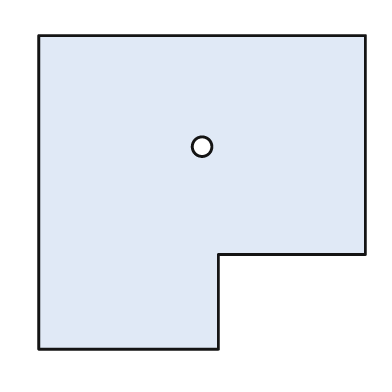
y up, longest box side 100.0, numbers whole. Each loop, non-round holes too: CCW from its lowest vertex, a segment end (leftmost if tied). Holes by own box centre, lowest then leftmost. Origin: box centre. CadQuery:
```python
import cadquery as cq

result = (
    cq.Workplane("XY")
    .moveTo(-50.0, -48.0)
    .lineTo(5.0, -48.0)
    .lineTo(5.0, -19.0)
    .lineTo(50.0, -19.0)
    .lineTo(50.0, 48.0)
    .lineTo(-50.0, 48.0)
    .close()
    .moveTo(0.0, 14.0)
    .circle(3.0)
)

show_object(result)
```